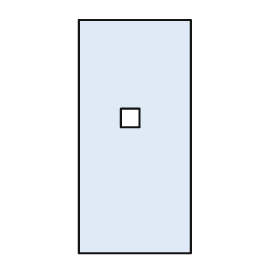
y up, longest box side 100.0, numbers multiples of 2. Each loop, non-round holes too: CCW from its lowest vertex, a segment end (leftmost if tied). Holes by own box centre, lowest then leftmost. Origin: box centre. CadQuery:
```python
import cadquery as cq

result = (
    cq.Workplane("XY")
    .moveTo(-24.0, -50.0)
    .lineTo(24.0, -50.0)
    .lineTo(24.0, 50.0)
    .lineTo(-24.0, 50.0)
    .close()
    .moveTo(-6.0, 4.0)
    .lineTo(2.0, 4.0)
    .lineTo(2.0, 12.0)
    .lineTo(-6.0, 12.0)
    .close()
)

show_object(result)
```